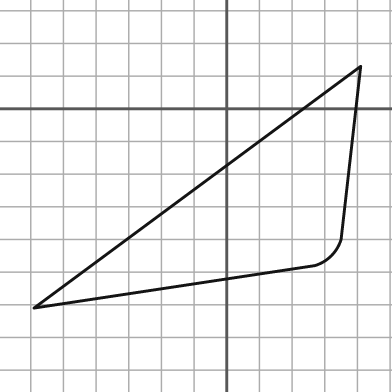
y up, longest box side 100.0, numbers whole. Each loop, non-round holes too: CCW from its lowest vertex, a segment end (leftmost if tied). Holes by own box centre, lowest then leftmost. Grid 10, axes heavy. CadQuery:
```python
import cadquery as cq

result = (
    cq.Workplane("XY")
    .moveTo(-59.0, -61.0)
    .lineTo(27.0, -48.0)
    .threePointArc((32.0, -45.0), (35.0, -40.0))
    .lineTo(41.0, 13.0)
    .close()
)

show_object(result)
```